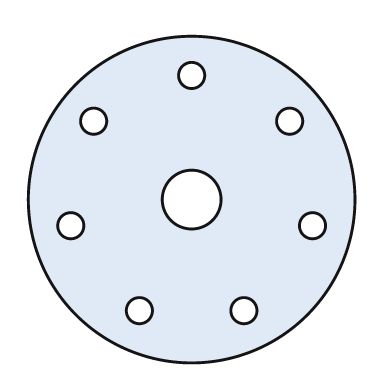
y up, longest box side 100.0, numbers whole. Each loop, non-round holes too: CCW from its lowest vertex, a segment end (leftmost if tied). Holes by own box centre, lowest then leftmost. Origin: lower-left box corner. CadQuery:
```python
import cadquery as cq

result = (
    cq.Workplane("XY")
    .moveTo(50.0, 50.0)
    .circle(50.0)
    .moveTo(34.0, 16.0)
    .circle(4.0)
    .moveTo(66.0, 16.0)
    .circle(4.0)
    .moveTo(13.0, 42.0)
    .circle(4.0)
    .moveTo(87.0, 42.0)
    .circle(4.0)
    .moveTo(50.0, 50.0)
    .circle(9.0)
    .moveTo(20.0, 74.0)
    .circle(4.0)
    .moveTo(80.0, 74.0)
    .circle(4.0)
    .moveTo(50.0, 88.0)
    .circle(4.0)
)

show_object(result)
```